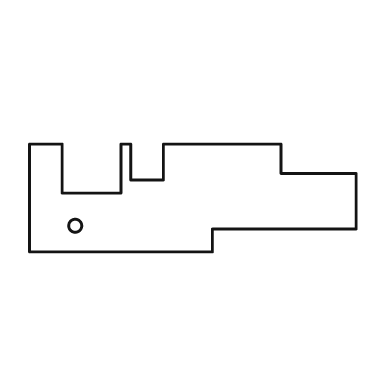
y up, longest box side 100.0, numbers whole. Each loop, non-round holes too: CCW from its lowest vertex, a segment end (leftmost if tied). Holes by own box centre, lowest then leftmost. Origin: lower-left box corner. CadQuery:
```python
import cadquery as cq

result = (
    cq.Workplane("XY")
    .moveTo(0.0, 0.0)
    .lineTo(56.0, 0.0)
    .lineTo(56.0, 7.0)
    .lineTo(100.0, 7.0)
    .lineTo(100.0, 24.0)
    .lineTo(77.0, 24.0)
    .lineTo(77.0, 33.0)
    .lineTo(41.0, 33.0)
    .lineTo(41.0, 22.0)
    .lineTo(31.0, 22.0)
    .lineTo(31.0, 33.0)
    .lineTo(28.0, 33.0)
    .lineTo(28.0, 18.0)
    .lineTo(10.0, 18.0)
    .lineTo(10.0, 33.0)
    .lineTo(0.0, 33.0)
    .close()
    .moveTo(14.0, 8.0)
    .circle(2.0)
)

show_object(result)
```